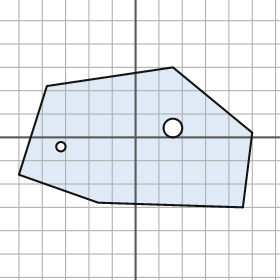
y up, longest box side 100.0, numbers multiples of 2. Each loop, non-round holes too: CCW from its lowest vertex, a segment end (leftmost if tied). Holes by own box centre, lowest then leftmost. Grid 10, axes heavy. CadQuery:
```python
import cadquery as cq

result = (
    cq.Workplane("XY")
    .moveTo(46.0, -30.0)
    .lineTo(50.0, 2.0)
    .lineTo(16.0, 30.0)
    .lineTo(-38.0, 22.0)
    .lineTo(-50.0, -16.0)
    .lineTo(-16.0, -28.0)
    .close()
    .moveTo(-32.0, -4.0)
    .circle(2.0)
    .moveTo(16.0, 4.0)
    .circle(4.0)
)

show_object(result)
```